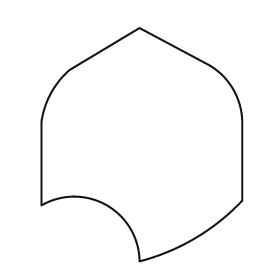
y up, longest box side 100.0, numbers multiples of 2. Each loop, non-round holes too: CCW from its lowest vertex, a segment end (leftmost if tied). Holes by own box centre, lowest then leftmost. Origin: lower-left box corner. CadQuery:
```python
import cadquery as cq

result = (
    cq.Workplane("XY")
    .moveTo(42.0, 0.0)
    .threePointArc((66.0, 10.0), (86.0, 26.0))
    .lineTo(86.0, 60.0)
    .threePointArc((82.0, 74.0), (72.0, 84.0))
    .lineTo(42.0, 100.0)
    .lineTo(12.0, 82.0)
    .threePointArc((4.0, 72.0), (0.0, 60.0))
    .lineTo(0.0, 24.0)
    .threePointArc((28.0, 24.0), (42.0, 0.0))
    .close()
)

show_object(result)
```